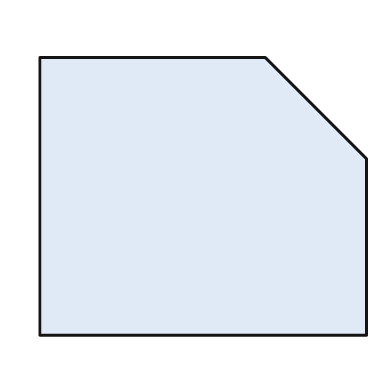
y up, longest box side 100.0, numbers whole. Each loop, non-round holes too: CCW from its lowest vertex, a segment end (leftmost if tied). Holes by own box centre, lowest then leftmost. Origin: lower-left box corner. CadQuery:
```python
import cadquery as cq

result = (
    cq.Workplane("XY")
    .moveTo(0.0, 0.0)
    .lineTo(100.0, 0.0)
    .lineTo(100.0, 54.0)
    .lineTo(69.0, 85.0)
    .lineTo(0.0, 85.0)
    .close()
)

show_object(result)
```